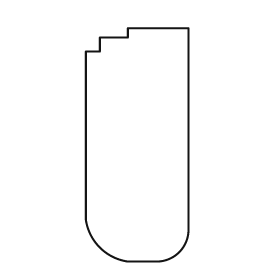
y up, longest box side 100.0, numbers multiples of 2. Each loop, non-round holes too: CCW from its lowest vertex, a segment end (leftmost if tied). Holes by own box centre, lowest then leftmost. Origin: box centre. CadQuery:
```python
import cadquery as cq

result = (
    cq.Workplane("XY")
    .moveTo(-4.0, -50.0)
    .lineTo(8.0, -50.0)
    .threePointArc((18.0, -46.0), (22.0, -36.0))
    .lineTo(22.0, 50.0)
    .lineTo(-4.0, 50.0)
    .lineTo(-4.0, 46.0)
    .lineTo(-16.0, 46.0)
    .lineTo(-16.0, 40.0)
    .lineTo(-22.0, 40.0)
    .lineTo(-22.0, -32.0)
    .threePointArc((-16.0, -44.0), (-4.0, -50.0))
    .close()
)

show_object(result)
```